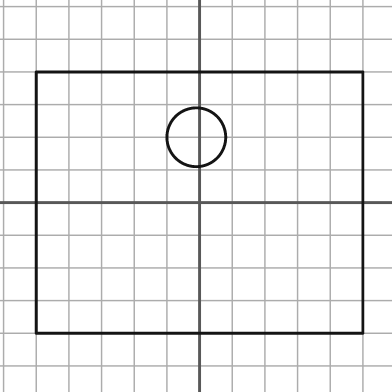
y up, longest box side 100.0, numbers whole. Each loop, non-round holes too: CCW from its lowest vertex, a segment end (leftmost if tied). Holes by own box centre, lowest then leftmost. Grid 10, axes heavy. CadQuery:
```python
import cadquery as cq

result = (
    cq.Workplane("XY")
    .moveTo(-50.0, -40.0)
    .lineTo(50.0, -40.0)
    .lineTo(50.0, 40.0)
    .lineTo(-50.0, 40.0)
    .close()
    .moveTo(-1.0, 20.0)
    .circle(9.0)
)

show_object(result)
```